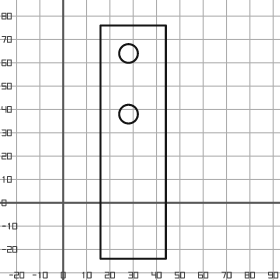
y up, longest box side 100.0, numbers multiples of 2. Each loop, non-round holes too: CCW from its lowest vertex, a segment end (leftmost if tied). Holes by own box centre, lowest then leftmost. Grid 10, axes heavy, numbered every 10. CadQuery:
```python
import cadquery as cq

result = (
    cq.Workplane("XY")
    .moveTo(16.0, -24.0)
    .lineTo(44.0, -24.0)
    .lineTo(44.0, 76.0)
    .lineTo(16.0, 76.0)
    .close()
    .moveTo(28.0, 38.0)
    .circle(4.0)
    .moveTo(28.0, 64.0)
    .circle(4.0)
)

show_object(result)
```